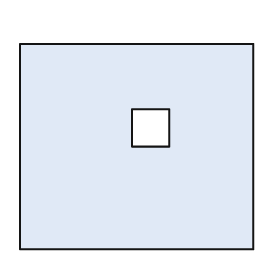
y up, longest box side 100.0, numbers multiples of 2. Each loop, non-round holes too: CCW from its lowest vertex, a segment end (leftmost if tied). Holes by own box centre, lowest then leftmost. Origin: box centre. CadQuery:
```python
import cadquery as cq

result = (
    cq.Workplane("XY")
    .moveTo(-50.0, -44.0)
    .lineTo(50.0, -44.0)
    .lineTo(50.0, 44.0)
    .lineTo(-50.0, 44.0)
    .close()
    .moveTo(-2.0, 0.0)
    .lineTo(14.0, 0.0)
    .lineTo(14.0, 16.0)
    .lineTo(-2.0, 16.0)
    .close()
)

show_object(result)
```